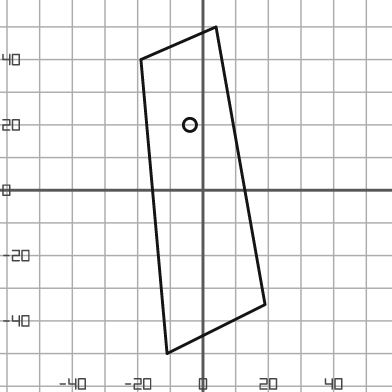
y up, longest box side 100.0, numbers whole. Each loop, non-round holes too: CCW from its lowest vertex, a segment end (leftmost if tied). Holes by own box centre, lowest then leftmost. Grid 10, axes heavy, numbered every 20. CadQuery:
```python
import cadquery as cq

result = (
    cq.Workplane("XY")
    .moveTo(-11.0, -50.0)
    .lineTo(19.0, -35.0)
    .lineTo(4.0, 50.0)
    .lineTo(-19.0, 40.0)
    .close()
    .moveTo(-4.0, 20.0)
    .circle(2.0)
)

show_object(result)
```